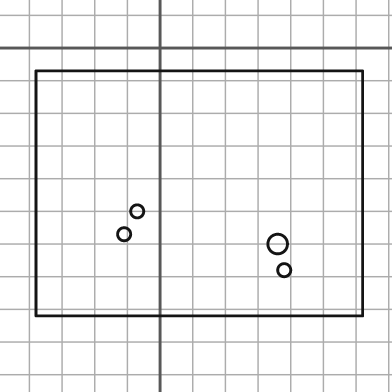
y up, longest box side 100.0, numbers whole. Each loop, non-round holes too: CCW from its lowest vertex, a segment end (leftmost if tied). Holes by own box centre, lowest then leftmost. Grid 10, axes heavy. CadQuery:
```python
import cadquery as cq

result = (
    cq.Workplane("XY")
    .moveTo(-38.0, -82.0)
    .lineTo(62.0, -82.0)
    .lineTo(62.0, -7.0)
    .lineTo(-38.0, -7.0)
    .close()
    .moveTo(38.0, -68.0)
    .circle(2.0)
    .moveTo(36.0, -60.0)
    .circle(3.0)
    .moveTo(-11.0, -57.0)
    .circle(2.0)
    .moveTo(-7.0, -50.0)
    .circle(2.0)
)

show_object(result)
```